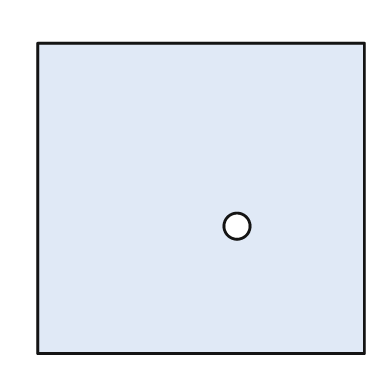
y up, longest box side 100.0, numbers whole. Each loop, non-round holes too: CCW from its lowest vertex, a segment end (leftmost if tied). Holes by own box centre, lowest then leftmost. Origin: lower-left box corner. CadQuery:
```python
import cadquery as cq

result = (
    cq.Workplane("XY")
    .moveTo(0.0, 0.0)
    .lineTo(100.0, 0.0)
    .lineTo(100.0, 95.0)
    .lineTo(0.0, 95.0)
    .close()
    .moveTo(61.0, 39.0)
    .circle(4.0)
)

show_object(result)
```